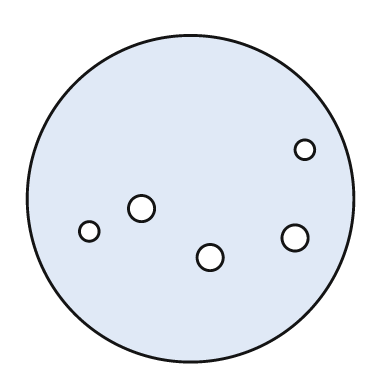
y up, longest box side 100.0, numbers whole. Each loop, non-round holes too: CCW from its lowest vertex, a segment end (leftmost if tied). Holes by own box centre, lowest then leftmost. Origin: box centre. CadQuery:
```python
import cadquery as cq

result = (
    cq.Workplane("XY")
    .moveTo(0.0, 0.0)
    .circle(50.0)
    .moveTo(6.0, -18.0)
    .circle(4.0)
    .moveTo(32.0, -12.0)
    .circle(4.0)
    .moveTo(-31.0, -10.0)
    .circle(3.0)
    .moveTo(-15.0, -3.0)
    .circle(4.0)
    .moveTo(35.0, 15.0)
    .circle(3.0)
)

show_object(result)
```